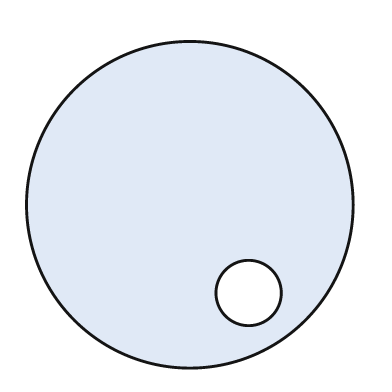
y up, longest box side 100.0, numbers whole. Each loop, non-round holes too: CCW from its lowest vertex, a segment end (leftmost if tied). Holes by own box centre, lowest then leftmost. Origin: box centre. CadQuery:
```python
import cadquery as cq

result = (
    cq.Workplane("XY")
    .moveTo(0.0, 0.0)
    .circle(50.0)
    .moveTo(18.0, -27.0)
    .circle(10.0)
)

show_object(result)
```